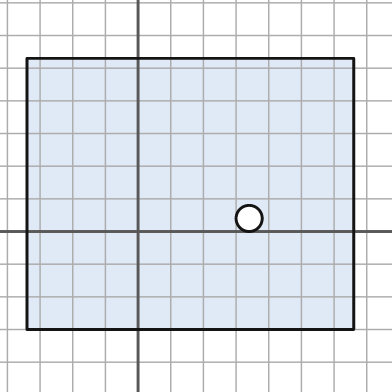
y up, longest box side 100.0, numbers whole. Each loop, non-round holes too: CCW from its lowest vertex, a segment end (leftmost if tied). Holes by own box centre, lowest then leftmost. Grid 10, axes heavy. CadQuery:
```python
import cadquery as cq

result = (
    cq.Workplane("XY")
    .moveTo(-34.0, -30.0)
    .lineTo(66.0, -30.0)
    .lineTo(66.0, 53.0)
    .lineTo(-34.0, 53.0)
    .close()
    .moveTo(34.0, 4.0)
    .circle(4.0)
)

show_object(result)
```